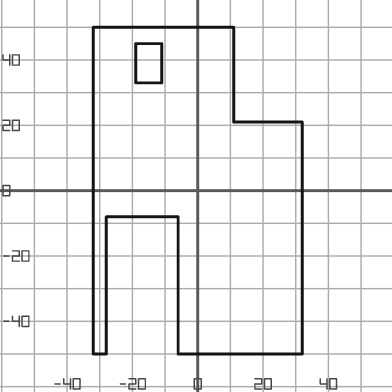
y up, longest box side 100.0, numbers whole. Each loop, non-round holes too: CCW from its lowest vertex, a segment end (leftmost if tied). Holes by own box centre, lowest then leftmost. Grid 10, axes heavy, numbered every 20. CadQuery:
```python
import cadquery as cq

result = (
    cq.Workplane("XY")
    .moveTo(-32.0, -50.0)
    .lineTo(-28.0, -50.0)
    .lineTo(-28.0, -8.0)
    .lineTo(-6.0, -8.0)
    .lineTo(-6.0, -50.0)
    .lineTo(32.0, -50.0)
    .lineTo(32.0, 21.0)
    .lineTo(11.0, 21.0)
    .lineTo(11.0, 50.0)
    .lineTo(-32.0, 50.0)
    .close()
    .moveTo(-19.0, 33.0)
    .lineTo(-11.0, 33.0)
    .lineTo(-11.0, 45.0)
    .lineTo(-19.0, 45.0)
    .close()
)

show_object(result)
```